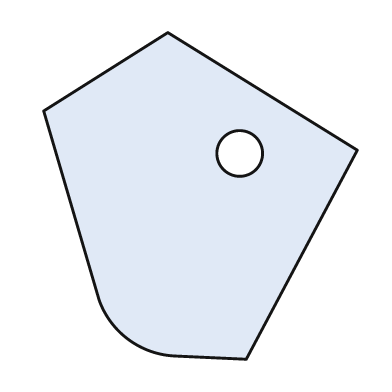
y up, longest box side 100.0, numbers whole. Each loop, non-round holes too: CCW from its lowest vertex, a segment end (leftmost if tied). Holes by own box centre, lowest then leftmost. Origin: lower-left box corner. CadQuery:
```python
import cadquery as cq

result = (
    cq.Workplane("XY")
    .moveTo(62.0, 0.0)
    .lineTo(96.0, 64.0)
    .lineTo(38.0, 100.0)
    .lineTo(0.0, 76.0)
    .lineTo(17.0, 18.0)
    .threePointArc((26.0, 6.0), (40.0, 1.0))
    .close()
    .moveTo(60.0, 63.0)
    .circle(7.0)
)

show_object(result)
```